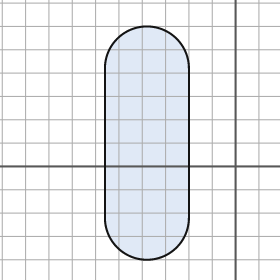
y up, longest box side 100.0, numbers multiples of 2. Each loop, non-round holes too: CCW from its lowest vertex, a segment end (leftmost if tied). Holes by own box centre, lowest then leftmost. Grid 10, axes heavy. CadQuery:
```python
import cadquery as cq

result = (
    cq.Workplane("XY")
    .moveTo(-56.0, -22.0)
    .threePointArc((-38.0, -40.0), (-20.0, -22.0))
    .lineTo(-20.0, 42.0)
    .threePointArc((-38.0, 60.0), (-56.0, 42.0))
    .close()
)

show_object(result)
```